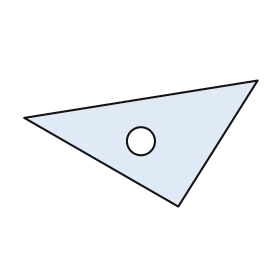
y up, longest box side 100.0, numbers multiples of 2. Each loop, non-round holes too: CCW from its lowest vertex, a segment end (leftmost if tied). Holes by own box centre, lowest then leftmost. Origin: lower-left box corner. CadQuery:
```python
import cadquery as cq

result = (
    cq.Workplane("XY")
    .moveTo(66.0, 0.0)
    .lineTo(100.0, 54.0)
    .lineTo(0.0, 38.0)
    .close()
    .moveTo(50.0, 28.0)
    .circle(6.0)
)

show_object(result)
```